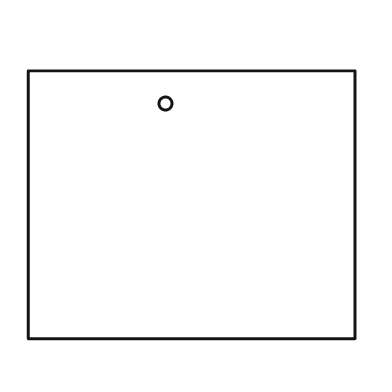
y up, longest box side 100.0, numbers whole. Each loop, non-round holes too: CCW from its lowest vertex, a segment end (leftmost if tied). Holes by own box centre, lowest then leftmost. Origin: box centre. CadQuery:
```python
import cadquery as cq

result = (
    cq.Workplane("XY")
    .moveTo(-50.0, -41.0)
    .lineTo(50.0, -41.0)
    .lineTo(50.0, 41.0)
    .lineTo(-50.0, 41.0)
    .close()
    .moveTo(-8.0, 31.0)
    .circle(2.0)
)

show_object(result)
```